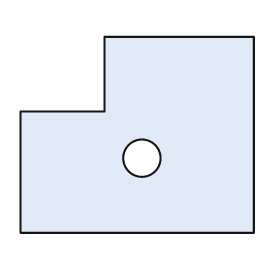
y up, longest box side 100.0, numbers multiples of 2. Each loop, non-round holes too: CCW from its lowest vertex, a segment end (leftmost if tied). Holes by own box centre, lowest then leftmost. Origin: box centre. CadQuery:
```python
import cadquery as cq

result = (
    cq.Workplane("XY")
    .moveTo(-50.0, -42.0)
    .lineTo(50.0, -42.0)
    .lineTo(50.0, 42.0)
    .lineTo(-14.0, 42.0)
    .lineTo(-14.0, 10.0)
    .lineTo(-50.0, 10.0)
    .close()
    .moveTo(2.0, -10.0)
    .circle(8.0)
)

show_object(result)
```